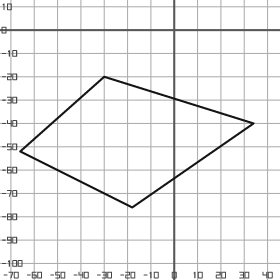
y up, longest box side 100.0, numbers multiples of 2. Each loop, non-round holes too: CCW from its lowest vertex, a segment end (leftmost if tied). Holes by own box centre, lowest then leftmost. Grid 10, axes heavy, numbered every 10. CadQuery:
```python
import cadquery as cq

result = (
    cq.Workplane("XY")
    .moveTo(-18.0, -76.0)
    .lineTo(34.0, -40.0)
    .lineTo(-30.0, -20.0)
    .lineTo(-66.0, -52.0)
    .close()
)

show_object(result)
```